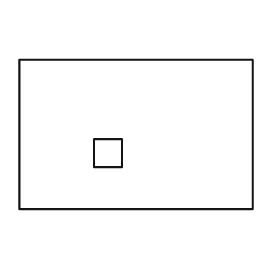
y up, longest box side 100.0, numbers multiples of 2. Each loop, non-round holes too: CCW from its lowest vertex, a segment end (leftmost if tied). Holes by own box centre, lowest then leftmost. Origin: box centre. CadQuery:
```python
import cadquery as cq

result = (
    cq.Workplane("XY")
    .moveTo(-50.0, -32.0)
    .lineTo(50.0, -32.0)
    .lineTo(50.0, 32.0)
    .lineTo(-50.0, 32.0)
    .close()
    .moveTo(-18.0, -14.0)
    .lineTo(-6.0, -14.0)
    .lineTo(-6.0, -2.0)
    .lineTo(-18.0, -2.0)
    .close()
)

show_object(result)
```